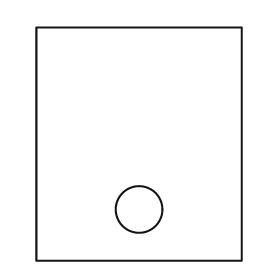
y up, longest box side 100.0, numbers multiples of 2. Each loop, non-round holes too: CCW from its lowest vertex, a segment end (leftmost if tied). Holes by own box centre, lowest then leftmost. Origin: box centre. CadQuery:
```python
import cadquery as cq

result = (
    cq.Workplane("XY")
    .moveTo(-44.0, -50.0)
    .lineTo(44.0, -50.0)
    .lineTo(44.0, 50.0)
    .lineTo(-44.0, 50.0)
    .close()
    .moveTo(0.0, -28.0)
    .circle(10.0)
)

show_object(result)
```